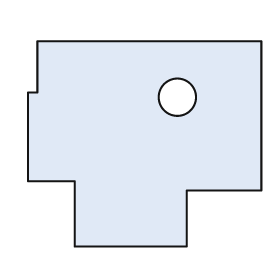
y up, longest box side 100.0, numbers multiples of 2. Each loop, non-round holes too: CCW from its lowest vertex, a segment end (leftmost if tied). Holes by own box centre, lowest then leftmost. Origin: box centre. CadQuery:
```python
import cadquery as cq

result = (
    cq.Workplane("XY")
    .moveTo(-30.0, -44.0)
    .lineTo(18.0, -44.0)
    .lineTo(18.0, -20.0)
    .lineTo(50.0, -20.0)
    .lineTo(50.0, 44.0)
    .lineTo(-46.0, 44.0)
    .lineTo(-46.0, 22.0)
    .lineTo(-50.0, 22.0)
    .lineTo(-50.0, -16.0)
    .lineTo(-30.0, -16.0)
    .close()
    .moveTo(14.0, 20.0)
    .circle(8.0)
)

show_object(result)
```